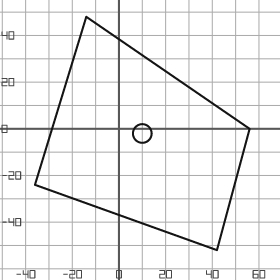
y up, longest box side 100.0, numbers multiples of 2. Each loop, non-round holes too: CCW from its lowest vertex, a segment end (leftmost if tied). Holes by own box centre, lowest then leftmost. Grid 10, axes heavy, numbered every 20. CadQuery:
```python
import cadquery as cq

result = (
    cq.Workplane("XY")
    .moveTo(42.0, -52.0)
    .lineTo(56.0, 0.0)
    .lineTo(-14.0, 48.0)
    .lineTo(-36.0, -24.0)
    .close()
    .moveTo(10.0, -2.0)
    .circle(4.0)
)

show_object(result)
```